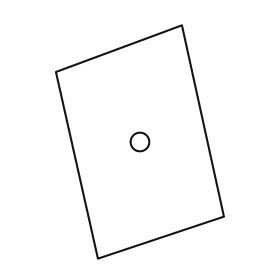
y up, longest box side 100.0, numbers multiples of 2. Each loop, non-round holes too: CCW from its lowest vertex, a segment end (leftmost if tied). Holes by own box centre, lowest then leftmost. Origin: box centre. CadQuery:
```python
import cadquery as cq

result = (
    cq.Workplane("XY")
    .moveTo(-18.0, -50.0)
    .lineTo(36.0, -32.0)
    .lineTo(18.0, 50.0)
    .lineTo(-36.0, 30.0)
    .close()
    .moveTo(0.0, 0.0)
    .circle(4.0)
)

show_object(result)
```